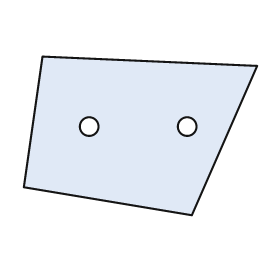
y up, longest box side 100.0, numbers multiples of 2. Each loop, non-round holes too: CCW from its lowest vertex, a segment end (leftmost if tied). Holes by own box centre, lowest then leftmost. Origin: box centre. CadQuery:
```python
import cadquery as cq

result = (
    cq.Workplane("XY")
    .moveTo(22.0, -34.0)
    .lineTo(50.0, 30.0)
    .lineTo(-42.0, 34.0)
    .lineTo(-50.0, -22.0)
    .close()
    .moveTo(-22.0, 4.0)
    .circle(4.0)
    .moveTo(20.0, 4.0)
    .circle(4.0)
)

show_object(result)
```